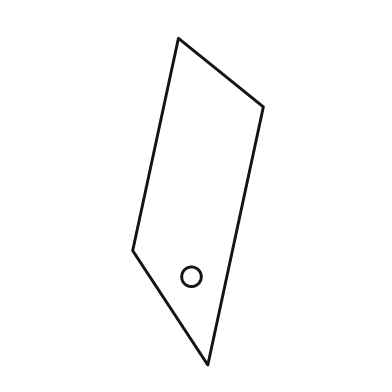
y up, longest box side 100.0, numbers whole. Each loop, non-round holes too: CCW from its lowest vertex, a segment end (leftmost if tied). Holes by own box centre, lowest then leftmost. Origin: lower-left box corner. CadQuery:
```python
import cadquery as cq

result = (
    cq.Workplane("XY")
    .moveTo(23.0, 0.0)
    .lineTo(40.0, 79.0)
    .lineTo(14.0, 100.0)
    .lineTo(0.0, 35.0)
    .close()
    .moveTo(18.0, 27.0)
    .circle(3.0)
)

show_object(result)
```